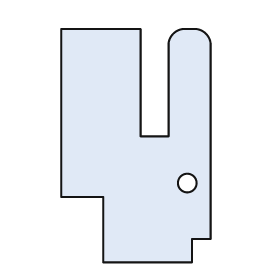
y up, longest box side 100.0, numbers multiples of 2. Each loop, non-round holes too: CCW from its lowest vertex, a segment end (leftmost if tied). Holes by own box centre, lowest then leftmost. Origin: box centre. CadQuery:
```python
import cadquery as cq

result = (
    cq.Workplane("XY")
    .moveTo(-14.0, -50.0)
    .lineTo(24.0, -50.0)
    .lineTo(24.0, -40.0)
    .lineTo(32.0, -40.0)
    .lineTo(32.0, 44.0)
    .threePointArc((30.0, 48.0), (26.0, 50.0))
    .lineTo(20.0, 50.0)
    .threePointArc((16.0, 48.0), (14.0, 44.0))
    .lineTo(14.0, 4.0)
    .lineTo(2.0, 4.0)
    .lineTo(2.0, 50.0)
    .lineTo(-32.0, 50.0)
    .lineTo(-32.0, -22.0)
    .lineTo(-14.0, -22.0)
    .close()
    .moveTo(22.0, -16.0)
    .circle(4.0)
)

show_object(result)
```